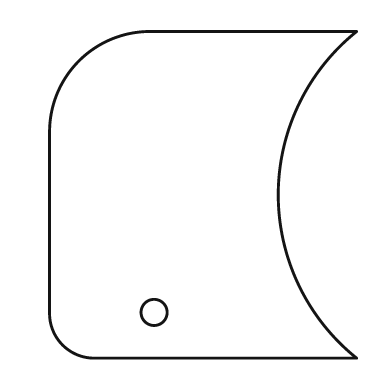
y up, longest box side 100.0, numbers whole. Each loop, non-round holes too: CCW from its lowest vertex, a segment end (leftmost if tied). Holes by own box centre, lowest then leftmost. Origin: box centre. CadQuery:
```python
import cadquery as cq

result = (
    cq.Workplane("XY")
    .moveTo(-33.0, -50.0)
    .lineTo(47.0, -50.0)
    .threePointArc((23.0, 0.0), (47.0, 50.0))
    .lineTo(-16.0, 50.0)
    .threePointArc((-38.0, 41.0), (-47.0, 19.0))
    .lineTo(-47.0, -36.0)
    .threePointArc((-43.0, -46.0), (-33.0, -50.0))
    .close()
    .moveTo(-15.0, -36.0)
    .circle(4.0)
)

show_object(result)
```